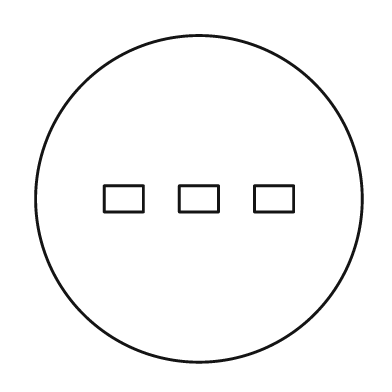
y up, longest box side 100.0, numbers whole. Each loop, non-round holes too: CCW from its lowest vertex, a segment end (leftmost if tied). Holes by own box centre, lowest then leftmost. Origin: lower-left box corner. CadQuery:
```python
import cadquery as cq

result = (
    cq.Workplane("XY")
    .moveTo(50.0, 50.0)
    .circle(50.0)
    .moveTo(21.0, 46.0)
    .lineTo(33.0, 46.0)
    .lineTo(33.0, 54.0)
    .lineTo(21.0, 54.0)
    .close()
    .moveTo(44.0, 46.0)
    .lineTo(56.0, 46.0)
    .lineTo(56.0, 54.0)
    .lineTo(44.0, 54.0)
    .close()
    .moveTo(67.0, 46.0)
    .lineTo(79.0, 46.0)
    .lineTo(79.0, 54.0)
    .lineTo(67.0, 54.0)
    .close()
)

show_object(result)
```